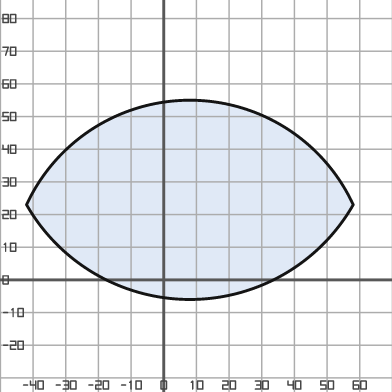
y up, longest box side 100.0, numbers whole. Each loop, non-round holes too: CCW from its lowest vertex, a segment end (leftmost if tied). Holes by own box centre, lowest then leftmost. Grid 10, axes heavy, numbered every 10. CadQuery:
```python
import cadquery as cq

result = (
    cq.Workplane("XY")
    .moveTo(-42.0, 23.0)
    .threePointArc((8.0, -6.0), (58.0, 23.0))
    .threePointArc((8.0, 55.0), (-42.0, 23.0))
    .close()
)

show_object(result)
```